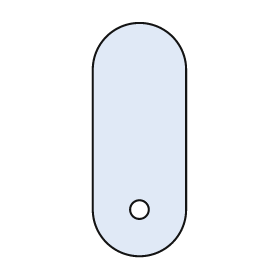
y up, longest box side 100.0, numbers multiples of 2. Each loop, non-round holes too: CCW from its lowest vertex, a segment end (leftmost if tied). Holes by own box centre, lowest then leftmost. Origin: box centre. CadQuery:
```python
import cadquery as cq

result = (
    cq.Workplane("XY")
    .moveTo(-20.0, -30.0)
    .threePointArc((0.0, -50.0), (20.0, -30.0))
    .lineTo(20.0, 30.0)
    .threePointArc((0.0, 50.0), (-20.0, 30.0))
    .close()
    .moveTo(0.0, -30.0)
    .circle(4.0)
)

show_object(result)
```